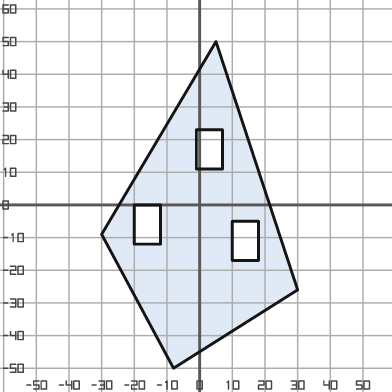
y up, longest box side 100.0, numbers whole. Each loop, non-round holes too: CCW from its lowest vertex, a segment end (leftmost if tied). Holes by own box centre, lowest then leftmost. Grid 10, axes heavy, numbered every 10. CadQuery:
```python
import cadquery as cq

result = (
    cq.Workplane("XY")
    .moveTo(-8.0, -50.0)
    .lineTo(30.0, -26.0)
    .lineTo(5.0, 50.0)
    .lineTo(-30.0, -9.0)
    .close()
    .moveTo(10.0, -17.0)
    .lineTo(18.0, -17.0)
    .lineTo(18.0, -5.0)
    .lineTo(10.0, -5.0)
    .close()
    .moveTo(-20.0, -12.0)
    .lineTo(-12.0, -12.0)
    .lineTo(-12.0, 0.0)
    .lineTo(-20.0, 0.0)
    .close()
    .moveTo(-1.0, 11.0)
    .lineTo(7.0, 11.0)
    .lineTo(7.0, 23.0)
    .lineTo(-1.0, 23.0)
    .close()
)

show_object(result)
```